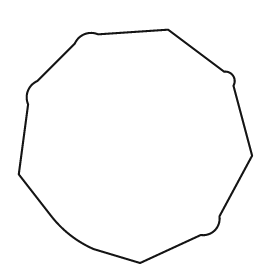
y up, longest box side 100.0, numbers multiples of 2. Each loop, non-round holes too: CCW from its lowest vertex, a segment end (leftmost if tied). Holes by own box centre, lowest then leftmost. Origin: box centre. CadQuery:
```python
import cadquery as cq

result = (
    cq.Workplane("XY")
    .moveTo(2.0, -50.0)
    .lineTo(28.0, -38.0)
    .threePointArc((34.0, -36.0), (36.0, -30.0))
    .lineTo(50.0, -4.0)
    .lineTo(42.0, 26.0)
    .threePointArc((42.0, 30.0), (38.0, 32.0))
    .lineTo(14.0, 50.0)
    .lineTo(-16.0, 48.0)
    .threePointArc((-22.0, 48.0), (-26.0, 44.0))
    .lineTo(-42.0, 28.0)
    .threePointArc((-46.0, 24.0), (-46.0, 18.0))
    .lineTo(-50.0, -12.0)
    .lineTo(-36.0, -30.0)
    .threePointArc((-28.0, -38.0), (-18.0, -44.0))
    .close()
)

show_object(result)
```